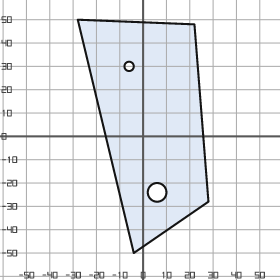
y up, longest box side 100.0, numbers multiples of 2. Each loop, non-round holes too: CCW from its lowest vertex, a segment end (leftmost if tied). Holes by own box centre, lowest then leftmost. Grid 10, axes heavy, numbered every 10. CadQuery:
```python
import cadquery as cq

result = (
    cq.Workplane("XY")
    .moveTo(-4.0, -50.0)
    .lineTo(28.0, -28.0)
    .lineTo(22.0, 48.0)
    .lineTo(-28.0, 50.0)
    .close()
    .moveTo(6.0, -24.0)
    .circle(4.0)
    .moveTo(-6.0, 30.0)
    .circle(2.0)
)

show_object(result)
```